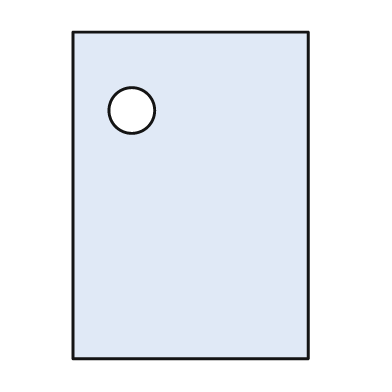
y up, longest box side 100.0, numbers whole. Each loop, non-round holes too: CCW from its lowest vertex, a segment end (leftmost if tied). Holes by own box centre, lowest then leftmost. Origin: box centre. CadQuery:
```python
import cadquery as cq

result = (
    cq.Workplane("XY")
    .moveTo(-36.0, -50.0)
    .lineTo(36.0, -50.0)
    .lineTo(36.0, 50.0)
    .lineTo(-36.0, 50.0)
    .close()
    .moveTo(-18.0, 26.0)
    .circle(7.0)
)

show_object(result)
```